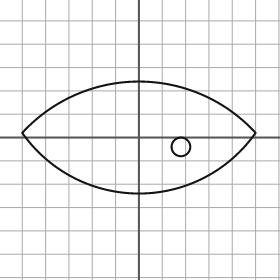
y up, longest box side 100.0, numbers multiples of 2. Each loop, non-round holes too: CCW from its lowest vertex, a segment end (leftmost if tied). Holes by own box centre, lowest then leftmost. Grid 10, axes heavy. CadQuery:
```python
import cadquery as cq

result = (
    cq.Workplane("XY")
    .moveTo(-50.0, 2.0)
    .threePointArc((0.0, -24.0), (50.0, 2.0))
    .threePointArc((0.0, 24.0), (-50.0, 2.0))
    .close()
    .moveTo(18.0, -4.0)
    .circle(4.0)
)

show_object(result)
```